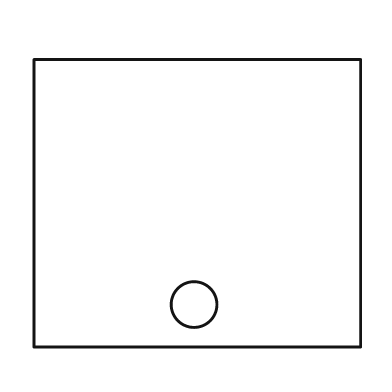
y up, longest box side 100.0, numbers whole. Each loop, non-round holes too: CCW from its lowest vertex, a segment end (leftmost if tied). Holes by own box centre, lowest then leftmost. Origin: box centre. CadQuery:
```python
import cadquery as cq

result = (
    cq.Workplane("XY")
    .moveTo(-50.0, -44.0)
    .lineTo(50.0, -44.0)
    .lineTo(50.0, 44.0)
    .lineTo(-50.0, 44.0)
    .close()
    .moveTo(-1.0, -31.0)
    .circle(7.0)
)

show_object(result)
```